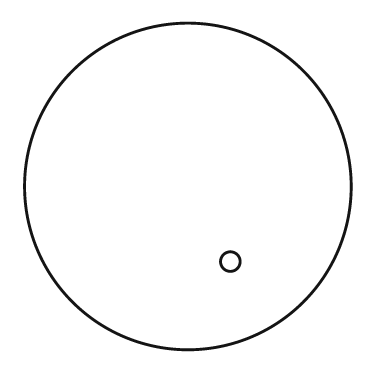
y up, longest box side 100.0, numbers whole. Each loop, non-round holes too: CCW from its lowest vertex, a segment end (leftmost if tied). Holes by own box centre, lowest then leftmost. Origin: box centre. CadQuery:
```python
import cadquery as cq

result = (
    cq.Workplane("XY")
    .moveTo(0.0, 0.0)
    .circle(50.0)
    .moveTo(13.0, -23.0)
    .circle(3.0)
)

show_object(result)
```